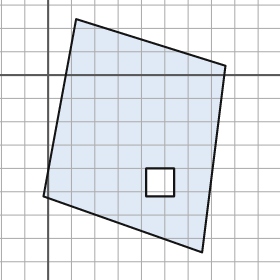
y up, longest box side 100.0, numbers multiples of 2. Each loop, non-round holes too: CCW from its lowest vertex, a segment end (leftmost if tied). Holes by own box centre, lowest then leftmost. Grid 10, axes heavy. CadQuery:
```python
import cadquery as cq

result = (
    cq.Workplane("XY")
    .moveTo(66.0, -76.0)
    .lineTo(76.0, 4.0)
    .lineTo(12.0, 24.0)
    .lineTo(-2.0, -52.0)
    .close()
    .moveTo(42.0, -52.0)
    .lineTo(54.0, -52.0)
    .lineTo(54.0, -40.0)
    .lineTo(42.0, -40.0)
    .close()
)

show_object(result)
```